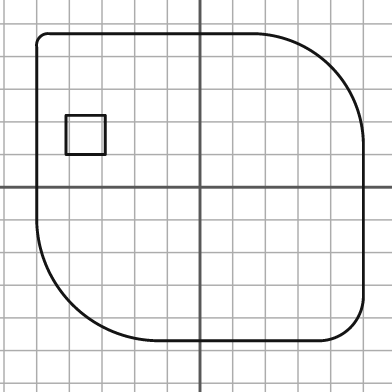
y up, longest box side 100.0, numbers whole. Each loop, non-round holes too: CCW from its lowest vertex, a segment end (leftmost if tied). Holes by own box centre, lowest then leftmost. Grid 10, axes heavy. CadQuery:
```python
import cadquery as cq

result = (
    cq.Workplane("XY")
    .moveTo(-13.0, -47.0)
    .lineTo(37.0, -47.0)
    .threePointArc((46.0, -43.0), (50.0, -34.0))
    .lineTo(50.0, 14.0)
    .threePointArc((40.0, 37.0), (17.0, 47.0))
    .lineTo(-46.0, 47.0)
    .threePointArc((-49.0, 46.0), (-50.0, 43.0))
    .lineTo(-50.0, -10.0)
    .threePointArc((-39.0, -36.0), (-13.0, -47.0))
    .close()
    .moveTo(-41.0, 10.0)
    .lineTo(-29.0, 10.0)
    .lineTo(-29.0, 22.0)
    .lineTo(-41.0, 22.0)
    .close()
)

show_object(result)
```